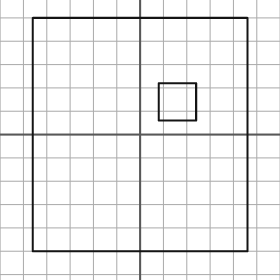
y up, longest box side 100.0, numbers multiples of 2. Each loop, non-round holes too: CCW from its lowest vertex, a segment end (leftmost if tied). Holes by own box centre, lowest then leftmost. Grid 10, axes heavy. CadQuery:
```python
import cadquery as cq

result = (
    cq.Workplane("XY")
    .moveTo(-46.0, -50.0)
    .lineTo(46.0, -50.0)
    .lineTo(46.0, 50.0)
    .lineTo(-46.0, 50.0)
    .close()
    .moveTo(8.0, 6.0)
    .lineTo(24.0, 6.0)
    .lineTo(24.0, 22.0)
    .lineTo(8.0, 22.0)
    .close()
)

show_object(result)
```